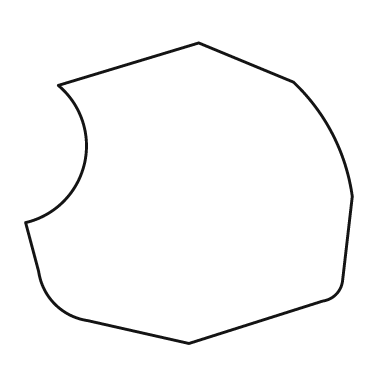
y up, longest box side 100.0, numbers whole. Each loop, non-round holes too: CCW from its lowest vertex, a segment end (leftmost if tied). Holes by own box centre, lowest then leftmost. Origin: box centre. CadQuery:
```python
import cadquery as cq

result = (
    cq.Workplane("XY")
    .moveTo(0.0, -46.0)
    .lineTo(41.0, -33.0)
    .threePointArc((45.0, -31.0), (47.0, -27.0))
    .lineTo(50.0, -1.0)
    .threePointArc((44.0, 18.0), (32.0, 34.0))
    .lineTo(3.0, 46.0)
    .lineTo(-40.0, 33.0)
    .threePointArc((-32.0, 9.0), (-50.0, -9.0))
    .lineTo(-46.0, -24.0)
    .threePointArc((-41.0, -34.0), (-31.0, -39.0))
    .close()
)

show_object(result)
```